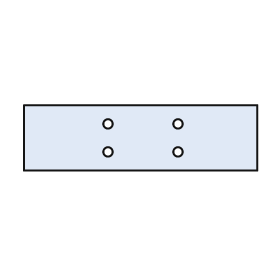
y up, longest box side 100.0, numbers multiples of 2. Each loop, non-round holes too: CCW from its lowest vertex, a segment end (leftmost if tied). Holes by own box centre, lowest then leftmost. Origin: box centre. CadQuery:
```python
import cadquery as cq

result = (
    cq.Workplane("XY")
    .moveTo(-50.0, -14.0)
    .lineTo(50.0, -14.0)
    .lineTo(50.0, 14.0)
    .lineTo(-50.0, 14.0)
    .close()
    .moveTo(-14.0, -6.0)
    .circle(2.0)
    .moveTo(16.0, -6.0)
    .circle(2.0)
    .moveTo(-14.0, 6.0)
    .circle(2.0)
    .moveTo(16.0, 6.0)
    .circle(2.0)
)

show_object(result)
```